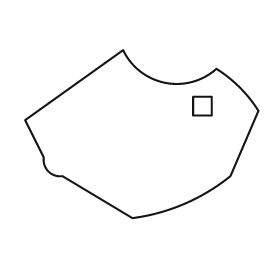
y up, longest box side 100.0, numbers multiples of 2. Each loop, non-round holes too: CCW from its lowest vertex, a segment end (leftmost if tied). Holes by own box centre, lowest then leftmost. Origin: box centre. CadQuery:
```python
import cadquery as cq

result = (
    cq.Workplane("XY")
    .moveTo(-4.0, -36.0)
    .threePointArc((18.0, -30.0), (38.0, -18.0))
    .lineTo(50.0, 10.0)
    .threePointArc((42.0, 20.0), (32.0, 28.0))
    .threePointArc((10.0, 22.0), (-8.0, 36.0))
    .lineTo(-50.0, 6.0)
    .lineTo(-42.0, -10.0)
    .threePointArc((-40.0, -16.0), (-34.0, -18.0))
    .close()
    .moveTo(22.0, 8.0)
    .lineTo(30.0, 8.0)
    .lineTo(30.0, 16.0)
    .lineTo(22.0, 16.0)
    .close()
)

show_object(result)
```